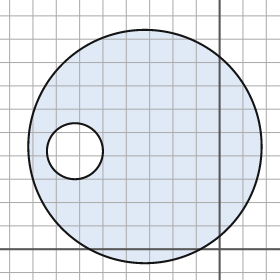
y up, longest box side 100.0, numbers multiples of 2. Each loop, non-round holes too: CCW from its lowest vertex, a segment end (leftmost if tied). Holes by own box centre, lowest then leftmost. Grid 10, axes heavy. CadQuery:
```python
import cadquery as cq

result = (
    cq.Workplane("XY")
    .moveTo(-32.0, 44.0)
    .circle(50.0)
    .moveTo(-62.0, 42.0)
    .circle(12.0)
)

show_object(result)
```